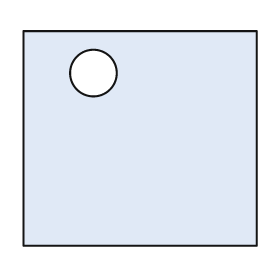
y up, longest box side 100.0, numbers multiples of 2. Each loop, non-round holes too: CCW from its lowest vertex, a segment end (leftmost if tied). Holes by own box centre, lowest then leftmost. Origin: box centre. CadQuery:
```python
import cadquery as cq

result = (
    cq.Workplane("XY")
    .moveTo(-50.0, -46.0)
    .lineTo(50.0, -46.0)
    .lineTo(50.0, 46.0)
    .lineTo(-50.0, 46.0)
    .close()
    .moveTo(-20.0, 28.0)
    .circle(10.0)
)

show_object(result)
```